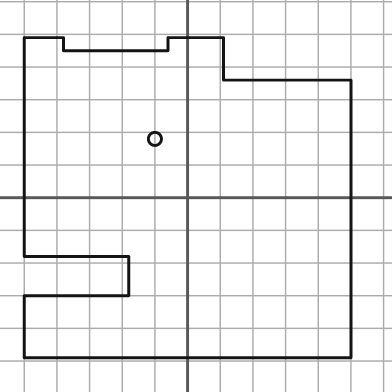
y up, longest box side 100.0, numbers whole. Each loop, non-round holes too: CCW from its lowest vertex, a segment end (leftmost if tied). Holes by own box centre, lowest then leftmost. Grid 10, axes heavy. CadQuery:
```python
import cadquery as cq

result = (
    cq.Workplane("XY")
    .moveTo(-50.0, -49.0)
    .lineTo(50.0, -49.0)
    .lineTo(50.0, 36.0)
    .lineTo(11.0, 36.0)
    .lineTo(11.0, 49.0)
    .lineTo(-6.0, 49.0)
    .lineTo(-6.0, 45.0)
    .lineTo(-38.0, 45.0)
    .lineTo(-38.0, 49.0)
    .lineTo(-50.0, 49.0)
    .lineTo(-50.0, -18.0)
    .lineTo(-18.0, -18.0)
    .lineTo(-18.0, -30.0)
    .lineTo(-50.0, -30.0)
    .close()
    .moveTo(-10.0, 18.0)
    .circle(2.0)
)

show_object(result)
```